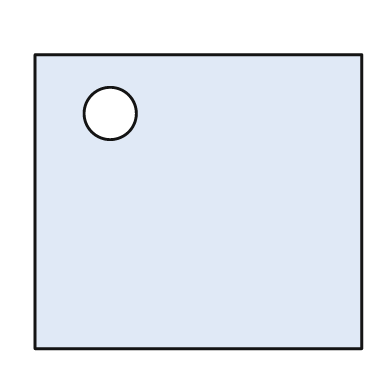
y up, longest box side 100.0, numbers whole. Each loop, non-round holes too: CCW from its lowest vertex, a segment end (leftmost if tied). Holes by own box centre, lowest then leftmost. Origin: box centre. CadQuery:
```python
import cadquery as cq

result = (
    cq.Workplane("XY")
    .moveTo(-50.0, -45.0)
    .lineTo(50.0, -45.0)
    .lineTo(50.0, 45.0)
    .lineTo(-50.0, 45.0)
    .close()
    .moveTo(-27.0, 27.0)
    .circle(8.0)
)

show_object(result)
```